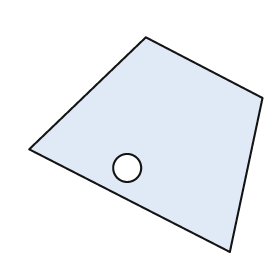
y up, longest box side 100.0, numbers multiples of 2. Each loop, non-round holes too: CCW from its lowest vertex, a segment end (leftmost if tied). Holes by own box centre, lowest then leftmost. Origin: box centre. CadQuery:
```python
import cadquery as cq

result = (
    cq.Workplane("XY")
    .moveTo(36.0, -46.0)
    .lineTo(50.0, 20.0)
    .lineTo(0.0, 46.0)
    .lineTo(-50.0, -2.0)
    .close()
    .moveTo(-8.0, -10.0)
    .circle(6.0)
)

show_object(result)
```